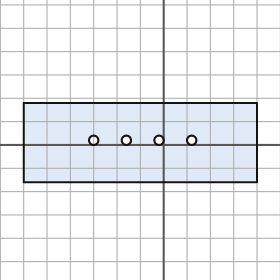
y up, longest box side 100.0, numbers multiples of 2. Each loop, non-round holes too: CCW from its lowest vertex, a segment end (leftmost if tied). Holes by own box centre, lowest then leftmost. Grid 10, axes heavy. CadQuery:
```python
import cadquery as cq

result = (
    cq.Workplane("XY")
    .moveTo(-60.0, -16.0)
    .lineTo(40.0, -16.0)
    .lineTo(40.0, 18.0)
    .lineTo(-60.0, 18.0)
    .close()
    .moveTo(-30.0, 2.0)
    .circle(2.0)
    .moveTo(-16.0, 2.0)
    .circle(2.0)
    .moveTo(-2.0, 2.0)
    .circle(2.0)
    .moveTo(12.0, 2.0)
    .circle(2.0)
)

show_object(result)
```